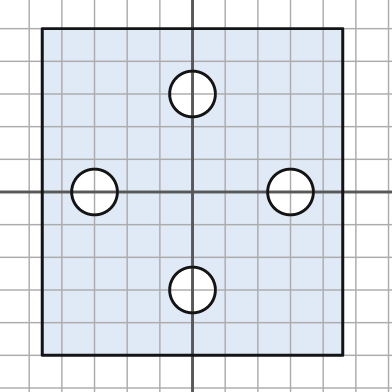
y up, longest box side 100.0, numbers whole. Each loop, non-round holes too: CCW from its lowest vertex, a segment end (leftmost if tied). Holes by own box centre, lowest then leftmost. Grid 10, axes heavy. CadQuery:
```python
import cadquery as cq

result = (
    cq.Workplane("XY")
    .moveTo(-46.0, -50.0)
    .lineTo(46.0, -50.0)
    .lineTo(46.0, 50.0)
    .lineTo(-46.0, 50.0)
    .close()
    .moveTo(0.0, -30.0)
    .circle(7.0)
    .moveTo(-30.0, 0.0)
    .circle(7.0)
    .moveTo(30.0, 0.0)
    .circle(7.0)
    .moveTo(0.0, 30.0)
    .circle(7.0)
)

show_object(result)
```